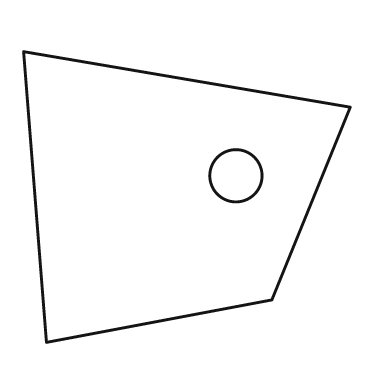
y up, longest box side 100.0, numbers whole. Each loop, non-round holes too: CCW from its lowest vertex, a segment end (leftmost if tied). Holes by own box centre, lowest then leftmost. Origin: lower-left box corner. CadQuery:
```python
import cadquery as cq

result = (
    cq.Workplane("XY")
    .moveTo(7.0, 0.0)
    .lineTo(76.0, 13.0)
    .lineTo(100.0, 72.0)
    .lineTo(0.0, 89.0)
    .close()
    .moveTo(65.0, 51.0)
    .circle(8.0)
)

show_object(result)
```